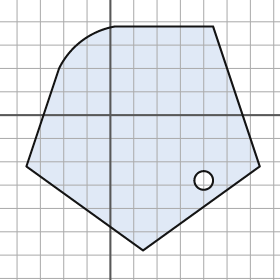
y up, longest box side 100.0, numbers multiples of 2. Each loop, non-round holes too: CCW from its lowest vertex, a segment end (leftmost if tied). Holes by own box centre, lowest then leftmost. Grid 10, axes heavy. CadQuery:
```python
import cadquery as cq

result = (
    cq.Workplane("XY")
    .moveTo(14.0, -58.0)
    .lineTo(64.0, -22.0)
    .lineTo(44.0, 38.0)
    .lineTo(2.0, 38.0)
    .threePointArc((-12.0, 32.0), (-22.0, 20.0))
    .lineTo(-36.0, -22.0)
    .close()
    .moveTo(40.0, -28.0)
    .circle(4.0)
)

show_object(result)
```